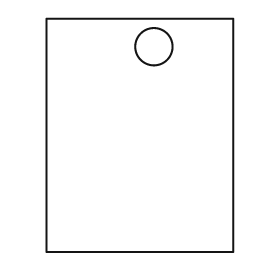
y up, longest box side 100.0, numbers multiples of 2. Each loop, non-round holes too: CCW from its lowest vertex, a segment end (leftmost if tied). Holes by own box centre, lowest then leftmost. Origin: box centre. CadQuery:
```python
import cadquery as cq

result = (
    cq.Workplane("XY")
    .moveTo(-40.0, -50.0)
    .lineTo(40.0, -50.0)
    .lineTo(40.0, 50.0)
    .lineTo(-40.0, 50.0)
    .close()
    .moveTo(6.0, 38.0)
    .circle(8.0)
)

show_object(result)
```